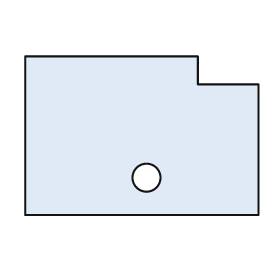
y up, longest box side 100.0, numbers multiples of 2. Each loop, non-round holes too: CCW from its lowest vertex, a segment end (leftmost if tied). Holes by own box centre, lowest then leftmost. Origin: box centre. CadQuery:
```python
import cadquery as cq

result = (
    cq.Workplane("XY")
    .moveTo(-50.0, -34.0)
    .lineTo(50.0, -34.0)
    .lineTo(50.0, 22.0)
    .lineTo(24.0, 22.0)
    .lineTo(24.0, 34.0)
    .lineTo(-50.0, 34.0)
    .close()
    .moveTo(2.0, -18.0)
    .circle(6.0)
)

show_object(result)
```